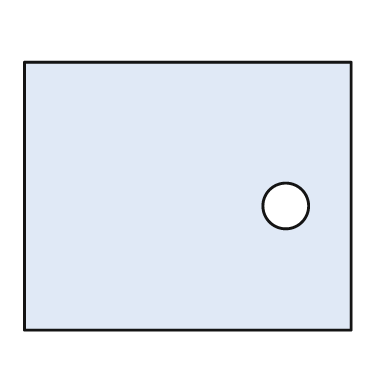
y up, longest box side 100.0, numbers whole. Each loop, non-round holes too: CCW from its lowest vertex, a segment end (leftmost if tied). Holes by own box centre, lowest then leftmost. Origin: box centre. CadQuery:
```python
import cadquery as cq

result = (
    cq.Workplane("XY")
    .moveTo(-50.0, -41.0)
    .lineTo(50.0, -41.0)
    .lineTo(50.0, 41.0)
    .lineTo(-50.0, 41.0)
    .close()
    .moveTo(30.0, -3.0)
    .circle(7.0)
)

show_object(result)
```